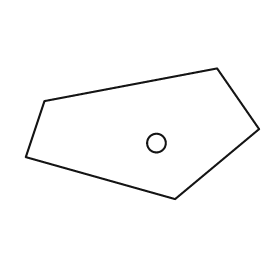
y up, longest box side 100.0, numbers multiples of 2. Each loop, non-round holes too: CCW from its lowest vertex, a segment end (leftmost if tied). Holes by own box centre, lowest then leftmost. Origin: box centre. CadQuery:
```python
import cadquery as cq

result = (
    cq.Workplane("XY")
    .moveTo(14.0, -28.0)
    .lineTo(50.0, 2.0)
    .lineTo(32.0, 28.0)
    .lineTo(-42.0, 14.0)
    .lineTo(-50.0, -10.0)
    .close()
    .moveTo(6.0, -4.0)
    .circle(4.0)
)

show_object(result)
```